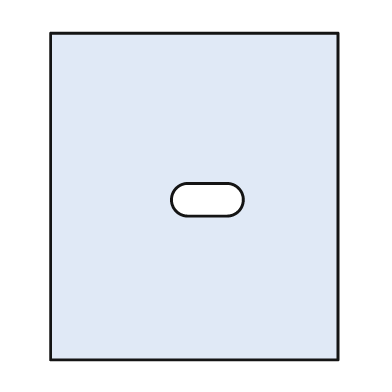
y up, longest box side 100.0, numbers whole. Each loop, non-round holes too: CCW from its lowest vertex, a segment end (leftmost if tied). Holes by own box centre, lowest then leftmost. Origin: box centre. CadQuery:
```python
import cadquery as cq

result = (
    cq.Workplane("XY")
    .moveTo(-44.0, -50.0)
    .lineTo(44.0, -50.0)
    .lineTo(44.0, 50.0)
    .lineTo(-44.0, 50.0)
    .close()
    .moveTo(-2.0, -6.0)
    .lineTo(10.0, -6.0)
    .threePointArc((15.0, -1.0), (10.0, 4.0))
    .lineTo(-2.0, 4.0)
    .threePointArc((-7.0, -1.0), (-2.0, -6.0))
    .close()
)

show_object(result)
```